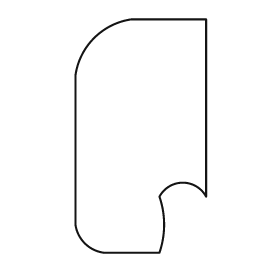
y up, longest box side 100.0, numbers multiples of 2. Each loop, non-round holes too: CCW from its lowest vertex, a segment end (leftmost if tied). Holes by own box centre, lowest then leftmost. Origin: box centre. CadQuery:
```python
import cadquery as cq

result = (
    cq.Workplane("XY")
    .moveTo(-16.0, -50.0)
    .lineTo(8.0, -50.0)
    .threePointArc((10.0, -38.0), (8.0, -26.0))
    .threePointArc((18.0, -20.0), (28.0, -26.0))
    .lineTo(28.0, 50.0)
    .lineTo(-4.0, 50.0)
    .threePointArc((-20.0, 42.0), (-28.0, 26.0))
    .lineTo(-28.0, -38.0)
    .threePointArc((-24.0, -46.0), (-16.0, -50.0))
    .close()
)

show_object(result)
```